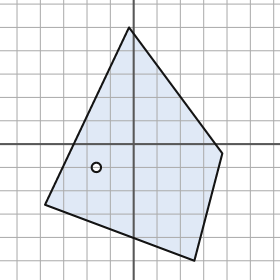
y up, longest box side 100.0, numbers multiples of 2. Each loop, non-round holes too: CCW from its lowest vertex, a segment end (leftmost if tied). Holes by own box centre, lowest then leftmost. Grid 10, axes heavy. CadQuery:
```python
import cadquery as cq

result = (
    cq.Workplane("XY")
    .moveTo(26.0, -50.0)
    .lineTo(38.0, -4.0)
    .lineTo(-2.0, 50.0)
    .lineTo(-38.0, -26.0)
    .close()
    .moveTo(-16.0, -10.0)
    .circle(2.0)
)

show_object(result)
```